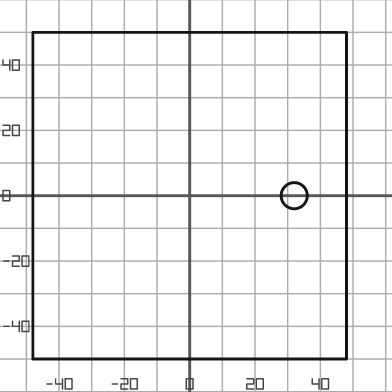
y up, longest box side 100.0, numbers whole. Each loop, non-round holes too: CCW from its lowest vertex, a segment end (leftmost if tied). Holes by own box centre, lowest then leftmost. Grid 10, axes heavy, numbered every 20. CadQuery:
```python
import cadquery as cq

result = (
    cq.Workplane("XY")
    .moveTo(-48.0, -50.0)
    .lineTo(48.0, -50.0)
    .lineTo(48.0, 50.0)
    .lineTo(-48.0, 50.0)
    .close()
    .moveTo(32.0, 0.0)
    .circle(4.0)
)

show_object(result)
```